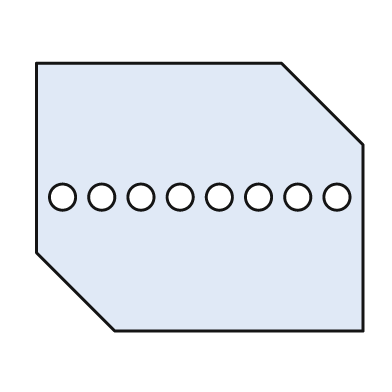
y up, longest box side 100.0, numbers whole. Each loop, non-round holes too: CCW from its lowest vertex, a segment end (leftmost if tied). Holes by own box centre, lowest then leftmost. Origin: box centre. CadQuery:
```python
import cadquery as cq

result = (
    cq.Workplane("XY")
    .moveTo(-26.0, -41.0)
    .lineTo(50.0, -41.0)
    .lineTo(50.0, 16.0)
    .lineTo(25.0, 41.0)
    .lineTo(-50.0, 41.0)
    .lineTo(-50.0, -17.0)
    .close()
    .moveTo(-42.0, 0.0)
    .circle(4.0)
    .moveTo(-30.0, 0.0)
    .circle(4.0)
    .moveTo(-18.0, 0.0)
    .circle(4.0)
    .moveTo(-6.0, 0.0)
    .circle(4.0)
    .moveTo(6.0, 0.0)
    .circle(4.0)
    .moveTo(18.0, 0.0)
    .circle(4.0)
    .moveTo(30.0, 0.0)
    .circle(4.0)
    .moveTo(42.0, 0.0)
    .circle(4.0)
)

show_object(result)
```